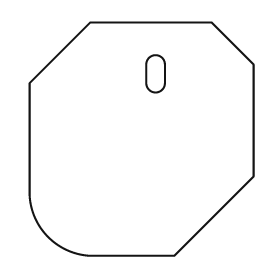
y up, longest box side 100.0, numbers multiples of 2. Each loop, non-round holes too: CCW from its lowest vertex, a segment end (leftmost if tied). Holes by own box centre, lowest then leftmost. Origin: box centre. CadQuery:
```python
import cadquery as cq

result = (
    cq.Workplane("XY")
    .moveTo(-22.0, -50.0)
    .lineTo(14.0, -50.0)
    .lineTo(48.0, -16.0)
    .lineTo(48.0, 32.0)
    .lineTo(30.0, 50.0)
    .lineTo(-22.0, 50.0)
    .lineTo(-48.0, 24.0)
    .lineTo(-48.0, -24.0)
    .threePointArc((-40.0, -42.0), (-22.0, -50.0))
    .close()
    .moveTo(2.0, 24.0)
    .threePointArc((6.0, 20.0), (10.0, 24.0))
    .lineTo(10.0, 32.0)
    .threePointArc((6.0, 36.0), (2.0, 32.0))
    .close()
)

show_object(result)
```